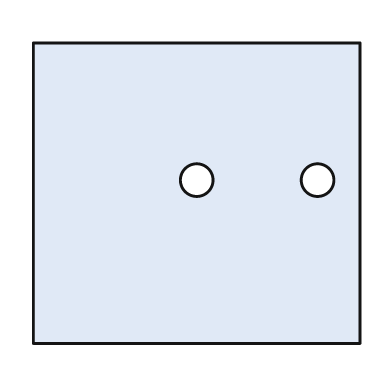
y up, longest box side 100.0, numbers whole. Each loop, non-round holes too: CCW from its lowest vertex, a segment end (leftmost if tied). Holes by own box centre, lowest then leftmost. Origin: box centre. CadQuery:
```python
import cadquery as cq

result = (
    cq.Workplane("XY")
    .moveTo(-50.0, -46.0)
    .lineTo(50.0, -46.0)
    .lineTo(50.0, 46.0)
    .lineTo(-50.0, 46.0)
    .close()
    .moveTo(0.0, 4.0)
    .circle(5.0)
    .moveTo(37.0, 4.0)
    .circle(5.0)
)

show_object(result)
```